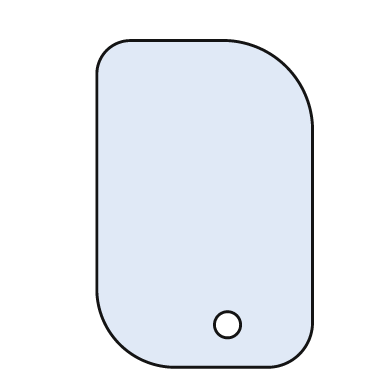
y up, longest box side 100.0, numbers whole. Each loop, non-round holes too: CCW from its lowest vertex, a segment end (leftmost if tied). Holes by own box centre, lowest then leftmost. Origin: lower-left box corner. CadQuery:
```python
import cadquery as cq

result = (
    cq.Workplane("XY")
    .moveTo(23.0, 0.0)
    .lineTo(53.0, 0.0)
    .threePointArc((62.0, 4.0), (66.0, 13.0))
    .lineTo(66.0, 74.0)
    .threePointArc((58.0, 92.0), (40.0, 100.0))
    .lineTo(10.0, 100.0)
    .threePointArc((3.0, 97.0), (0.0, 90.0))
    .lineTo(0.0, 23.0)
    .threePointArc((7.0, 7.0), (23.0, 0.0))
    .close()
    .moveTo(40.0, 13.0)
    .circle(4.0)
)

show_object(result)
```